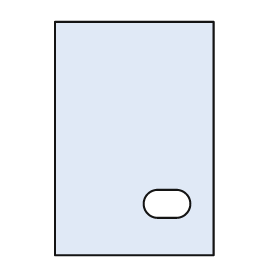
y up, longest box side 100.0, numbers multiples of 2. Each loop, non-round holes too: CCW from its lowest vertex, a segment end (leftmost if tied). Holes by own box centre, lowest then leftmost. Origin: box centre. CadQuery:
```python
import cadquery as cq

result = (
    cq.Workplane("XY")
    .moveTo(-34.0, -50.0)
    .lineTo(34.0, -50.0)
    .lineTo(34.0, 50.0)
    .lineTo(-34.0, 50.0)
    .close()
    .moveTo(10.0, -34.0)
    .lineTo(18.0, -34.0)
    .threePointArc((24.0, -28.0), (18.0, -22.0))
    .lineTo(10.0, -22.0)
    .threePointArc((4.0, -28.0), (10.0, -34.0))
    .close()
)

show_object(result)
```